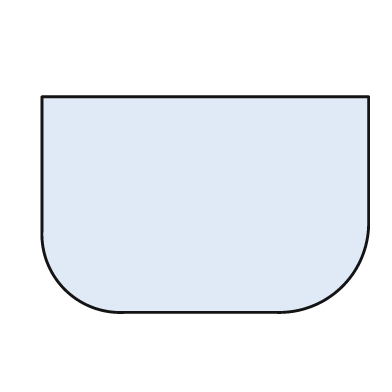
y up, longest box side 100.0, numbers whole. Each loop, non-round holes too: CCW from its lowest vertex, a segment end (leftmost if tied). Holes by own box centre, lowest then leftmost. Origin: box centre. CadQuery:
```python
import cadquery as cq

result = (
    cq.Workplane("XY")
    .moveTo(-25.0, -33.0)
    .lineTo(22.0, -33.0)
    .threePointArc((42.0, -25.0), (50.0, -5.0))
    .lineTo(50.0, 33.0)
    .lineTo(-50.0, 33.0)
    .lineTo(-50.0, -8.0)
    .threePointArc((-43.0, -26.0), (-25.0, -33.0))
    .close()
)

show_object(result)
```